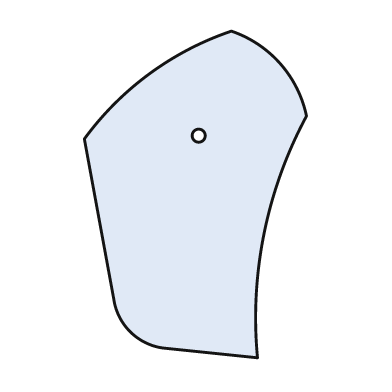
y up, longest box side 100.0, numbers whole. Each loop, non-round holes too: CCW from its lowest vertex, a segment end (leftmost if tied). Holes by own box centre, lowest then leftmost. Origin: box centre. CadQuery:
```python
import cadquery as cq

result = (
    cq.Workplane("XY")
    .moveTo(19.0, -50.0)
    .threePointArc((21.0, -12.0), (34.0, 24.0))
    .threePointArc((26.0, 40.0), (11.0, 50.0))
    .threePointArc((-14.0, 37.0), (-34.0, 17.0))
    .lineTo(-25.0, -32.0)
    .threePointArc((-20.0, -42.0), (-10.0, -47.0))
    .close()
    .moveTo(1.0, 18.0)
    .circle(2.0)
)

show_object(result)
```